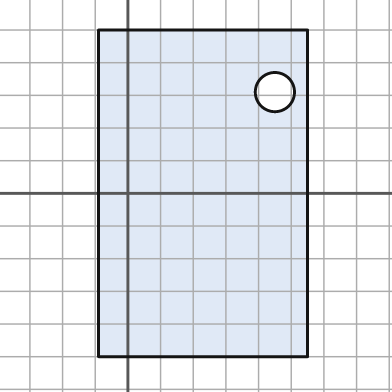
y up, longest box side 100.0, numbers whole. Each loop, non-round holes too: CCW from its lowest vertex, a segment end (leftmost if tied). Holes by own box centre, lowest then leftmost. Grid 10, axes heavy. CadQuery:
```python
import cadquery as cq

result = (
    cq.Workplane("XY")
    .moveTo(-9.0, -50.0)
    .lineTo(55.0, -50.0)
    .lineTo(55.0, 50.0)
    .lineTo(-9.0, 50.0)
    .close()
    .moveTo(45.0, 31.0)
    .circle(6.0)
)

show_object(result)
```